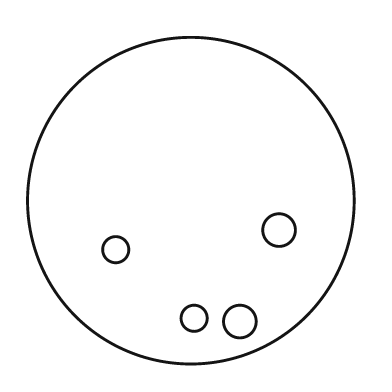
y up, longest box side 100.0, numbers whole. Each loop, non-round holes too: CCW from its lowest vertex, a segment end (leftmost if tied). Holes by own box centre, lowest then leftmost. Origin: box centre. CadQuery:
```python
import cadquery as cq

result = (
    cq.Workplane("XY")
    .moveTo(0.0, 0.0)
    .circle(50.0)
    .moveTo(15.0, -37.0)
    .circle(5.0)
    .moveTo(1.0, -36.0)
    .circle(4.0)
    .moveTo(-23.0, -15.0)
    .circle(4.0)
    .moveTo(27.0, -9.0)
    .circle(5.0)
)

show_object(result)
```